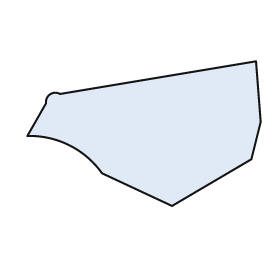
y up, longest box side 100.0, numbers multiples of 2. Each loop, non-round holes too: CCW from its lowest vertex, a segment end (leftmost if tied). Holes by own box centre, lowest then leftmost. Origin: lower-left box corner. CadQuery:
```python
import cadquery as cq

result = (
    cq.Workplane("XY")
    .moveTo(62.0, 0.0)
    .lineTo(96.0, 20.0)
    .lineTo(100.0, 36.0)
    .lineTo(98.0, 62.0)
    .lineTo(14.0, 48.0)
    .threePointArc((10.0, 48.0), (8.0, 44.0))
    .lineTo(0.0, 30.0)
    .threePointArc((18.0, 26.0), (32.0, 14.0))
    .close()
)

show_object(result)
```